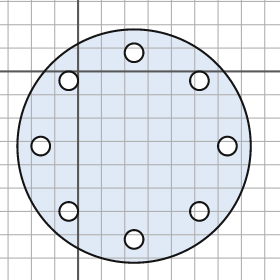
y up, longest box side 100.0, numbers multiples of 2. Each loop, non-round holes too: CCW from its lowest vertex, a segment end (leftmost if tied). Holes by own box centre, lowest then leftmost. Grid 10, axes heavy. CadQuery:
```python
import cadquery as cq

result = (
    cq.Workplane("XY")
    .moveTo(24.0, -32.0)
    .circle(50.0)
    .moveTo(24.0, -72.0)
    .circle(4.0)
    .moveTo(-4.0, -60.0)
    .circle(4.0)
    .moveTo(52.0, -60.0)
    .circle(4.0)
    .moveTo(-16.0, -32.0)
    .circle(4.0)
    .moveTo(64.0, -32.0)
    .circle(4.0)
    .moveTo(-4.0, -4.0)
    .circle(4.0)
    .moveTo(52.0, -4.0)
    .circle(4.0)
    .moveTo(24.0, 8.0)
    .circle(4.0)
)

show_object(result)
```